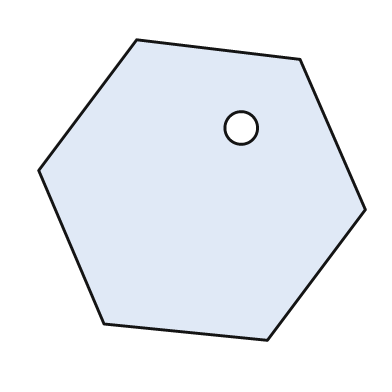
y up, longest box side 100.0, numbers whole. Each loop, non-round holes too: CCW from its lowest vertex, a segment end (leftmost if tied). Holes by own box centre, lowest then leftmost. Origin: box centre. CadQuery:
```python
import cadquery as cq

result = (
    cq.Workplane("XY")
    .moveTo(20.0, -46.0)
    .lineTo(50.0, -6.0)
    .lineTo(30.0, 40.0)
    .lineTo(-20.0, 46.0)
    .lineTo(-50.0, 6.0)
    .lineTo(-30.0, -41.0)
    .close()
    .moveTo(12.0, 19.0)
    .circle(5.0)
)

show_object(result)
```